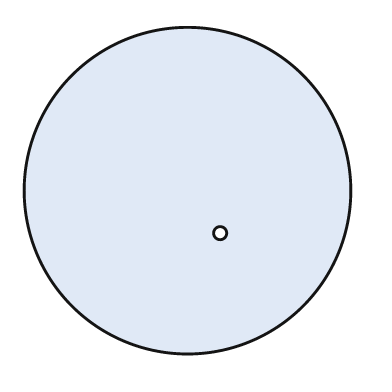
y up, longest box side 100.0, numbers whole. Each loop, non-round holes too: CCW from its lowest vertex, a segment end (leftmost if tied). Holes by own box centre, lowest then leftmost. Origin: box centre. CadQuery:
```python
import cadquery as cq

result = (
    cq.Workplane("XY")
    .moveTo(0.0, 0.0)
    .circle(50.0)
    .moveTo(10.0, -13.0)
    .circle(2.0)
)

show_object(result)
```